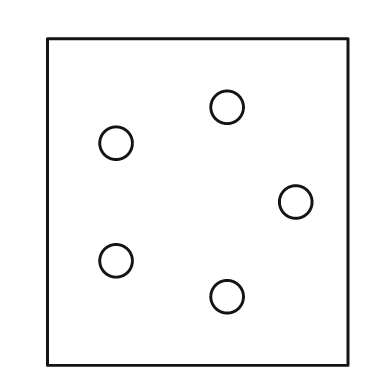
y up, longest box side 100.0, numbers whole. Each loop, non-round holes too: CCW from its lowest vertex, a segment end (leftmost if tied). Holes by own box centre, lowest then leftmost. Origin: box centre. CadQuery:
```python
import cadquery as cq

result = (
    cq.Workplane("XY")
    .moveTo(-46.0, -50.0)
    .lineTo(46.0, -50.0)
    .lineTo(46.0, 50.0)
    .lineTo(-46.0, 50.0)
    .close()
    .moveTo(9.0, -29.0)
    .circle(5.0)
    .moveTo(-25.0, -18.0)
    .circle(5.0)
    .moveTo(30.0, 0.0)
    .circle(5.0)
    .moveTo(-25.0, 18.0)
    .circle(5.0)
    .moveTo(9.0, 29.0)
    .circle(5.0)
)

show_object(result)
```